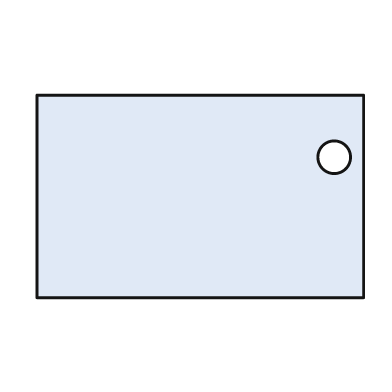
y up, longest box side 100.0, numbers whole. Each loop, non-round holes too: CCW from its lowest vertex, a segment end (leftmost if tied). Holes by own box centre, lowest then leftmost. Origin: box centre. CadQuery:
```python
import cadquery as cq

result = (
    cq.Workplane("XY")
    .moveTo(-50.0, -31.0)
    .lineTo(50.0, -31.0)
    .lineTo(50.0, 31.0)
    .lineTo(-50.0, 31.0)
    .close()
    .moveTo(41.0, 12.0)
    .circle(5.0)
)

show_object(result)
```